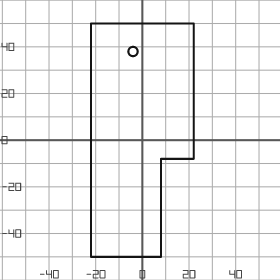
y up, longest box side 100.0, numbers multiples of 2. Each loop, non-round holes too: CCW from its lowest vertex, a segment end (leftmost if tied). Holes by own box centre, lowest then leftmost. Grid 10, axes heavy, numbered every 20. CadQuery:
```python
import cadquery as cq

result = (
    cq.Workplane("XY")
    .moveTo(-22.0, -50.0)
    .lineTo(8.0, -50.0)
    .lineTo(8.0, -8.0)
    .lineTo(22.0, -8.0)
    .lineTo(22.0, 50.0)
    .lineTo(-22.0, 50.0)
    .close()
    .moveTo(-4.0, 38.0)
    .circle(2.0)
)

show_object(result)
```